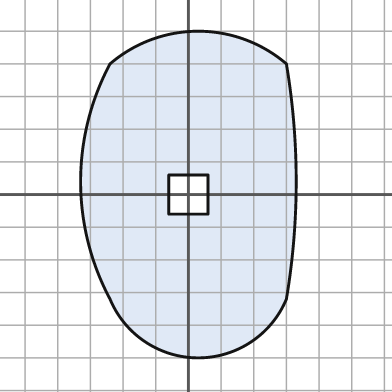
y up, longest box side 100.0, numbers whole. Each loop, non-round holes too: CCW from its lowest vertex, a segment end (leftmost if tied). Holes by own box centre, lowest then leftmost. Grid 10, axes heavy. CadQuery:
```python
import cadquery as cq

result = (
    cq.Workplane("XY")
    .moveTo(-24.0, -32.0)
    .threePointArc((3.0, -50.0), (30.0, -32.0))
    .threePointArc((33.0, 4.0), (30.0, 40.0))
    .threePointArc((3.0, 50.0), (-24.0, 40.0))
    .threePointArc((-33.0, 4.0), (-24.0, -32.0))
    .close()
    .moveTo(-6.0, -6.0)
    .lineTo(6.0, -6.0)
    .lineTo(6.0, 6.0)
    .lineTo(-6.0, 6.0)
    .close()
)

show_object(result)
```